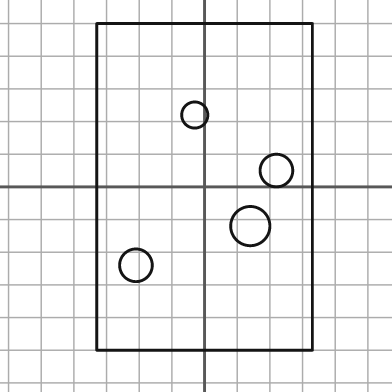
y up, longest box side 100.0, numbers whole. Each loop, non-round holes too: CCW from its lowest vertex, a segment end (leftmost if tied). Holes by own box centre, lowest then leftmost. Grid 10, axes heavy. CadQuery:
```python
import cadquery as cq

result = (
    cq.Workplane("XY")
    .moveTo(-33.0, -50.0)
    .lineTo(33.0, -50.0)
    .lineTo(33.0, 50.0)
    .lineTo(-33.0, 50.0)
    .close()
    .moveTo(-21.0, -24.0)
    .circle(5.0)
    .moveTo(14.0, -12.0)
    .circle(6.0)
    .moveTo(22.0, 5.0)
    .circle(5.0)
    .moveTo(-3.0, 22.0)
    .circle(4.0)
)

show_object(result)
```